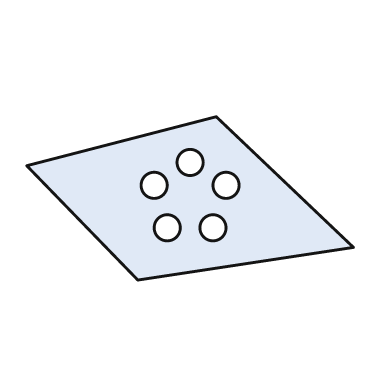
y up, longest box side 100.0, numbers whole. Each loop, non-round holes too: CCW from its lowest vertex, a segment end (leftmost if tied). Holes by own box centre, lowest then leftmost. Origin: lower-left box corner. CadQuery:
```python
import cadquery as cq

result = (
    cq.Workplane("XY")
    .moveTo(34.0, 0.0)
    .lineTo(100.0, 10.0)
    .lineTo(58.0, 50.0)
    .lineTo(0.0, 35.0)
    .close()
    .moveTo(43.0, 16.0)
    .circle(4.0)
    .moveTo(57.0, 16.0)
    .circle(4.0)
    .moveTo(39.0, 29.0)
    .circle(4.0)
    .moveTo(61.0, 29.0)
    .circle(4.0)
    .moveTo(50.0, 36.0)
    .circle(4.0)
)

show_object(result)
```